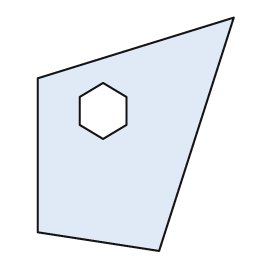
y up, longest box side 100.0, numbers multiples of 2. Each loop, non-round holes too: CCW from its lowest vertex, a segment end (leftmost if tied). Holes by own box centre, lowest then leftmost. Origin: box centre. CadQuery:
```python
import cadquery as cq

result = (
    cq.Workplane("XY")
    .moveTo(10.0, -50.0)
    .lineTo(42.0, 50.0)
    .lineTo(-42.0, 24.0)
    .lineTo(-42.0, -42.0)
    .close()
    .moveTo(-14.0, -2.0)
    .lineTo(-4.0, 4.0)
    .lineTo(-4.0, 16.0)
    .lineTo(-14.0, 22.0)
    .lineTo(-24.0, 16.0)
    .lineTo(-24.0, 4.0)
    .close()
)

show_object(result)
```